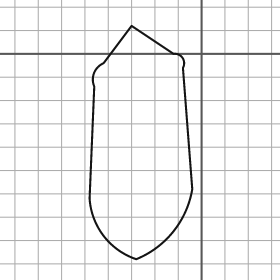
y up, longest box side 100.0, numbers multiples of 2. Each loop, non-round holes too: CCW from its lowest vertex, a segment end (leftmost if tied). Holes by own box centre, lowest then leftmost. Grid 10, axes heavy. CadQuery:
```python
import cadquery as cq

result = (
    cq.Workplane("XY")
    .moveTo(-28.0, -88.0)
    .threePointArc((-12.0, -76.0), (-4.0, -58.0))
    .lineTo(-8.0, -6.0)
    .threePointArc((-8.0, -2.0), (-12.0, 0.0))
    .lineTo(-30.0, 12.0)
    .lineTo(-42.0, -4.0)
    .threePointArc((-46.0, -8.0), (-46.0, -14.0))
    .lineTo(-48.0, -62.0)
    .threePointArc((-42.0, -78.0), (-28.0, -88.0))
    .close()
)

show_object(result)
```